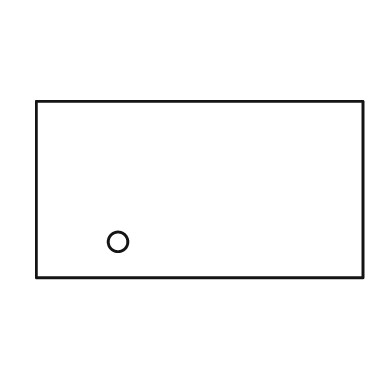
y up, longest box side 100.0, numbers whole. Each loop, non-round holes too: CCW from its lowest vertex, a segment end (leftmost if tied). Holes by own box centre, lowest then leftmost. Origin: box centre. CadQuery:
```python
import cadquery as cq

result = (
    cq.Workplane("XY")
    .moveTo(-50.0, -27.0)
    .lineTo(50.0, -27.0)
    .lineTo(50.0, 27.0)
    .lineTo(-50.0, 27.0)
    .close()
    .moveTo(-25.0, -16.0)
    .circle(3.0)
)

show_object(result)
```